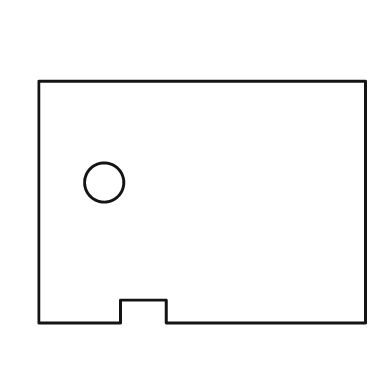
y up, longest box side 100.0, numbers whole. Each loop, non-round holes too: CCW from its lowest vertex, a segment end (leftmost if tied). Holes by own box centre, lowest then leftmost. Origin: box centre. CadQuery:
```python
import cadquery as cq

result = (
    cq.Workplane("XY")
    .moveTo(-50.0, -37.0)
    .lineTo(-25.0, -37.0)
    .lineTo(-25.0, -30.0)
    .lineTo(-11.0, -30.0)
    .lineTo(-11.0, -37.0)
    .lineTo(50.0, -37.0)
    .lineTo(50.0, 37.0)
    .lineTo(-50.0, 37.0)
    .close()
    .moveTo(-30.0, 6.0)
    .circle(6.0)
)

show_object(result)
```